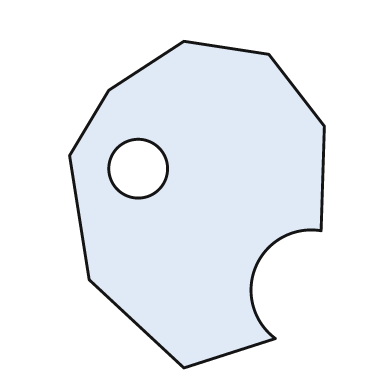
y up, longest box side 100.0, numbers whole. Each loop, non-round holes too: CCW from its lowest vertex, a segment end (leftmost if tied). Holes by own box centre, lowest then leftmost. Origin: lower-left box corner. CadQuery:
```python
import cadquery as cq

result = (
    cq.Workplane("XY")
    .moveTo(35.0, 0.0)
    .lineTo(63.0, 9.0)
    .threePointArc((57.0, 31.0), (77.0, 42.0))
    .lineTo(78.0, 74.0)
    .lineTo(61.0, 96.0)
    .lineTo(35.0, 100.0)
    .lineTo(12.0, 85.0)
    .lineTo(0.0, 65.0)
    .lineTo(6.0, 27.0)
    .close()
    .moveTo(21.0, 61.0)
    .circle(9.0)
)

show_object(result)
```